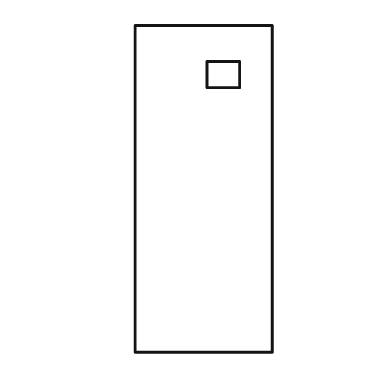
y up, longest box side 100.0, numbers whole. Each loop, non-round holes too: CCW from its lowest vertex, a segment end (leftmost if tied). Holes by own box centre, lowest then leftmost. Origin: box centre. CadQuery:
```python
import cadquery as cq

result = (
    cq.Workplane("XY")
    .moveTo(-21.0, -50.0)
    .lineTo(21.0, -50.0)
    .lineTo(21.0, 50.0)
    .lineTo(-21.0, 50.0)
    .close()
    .moveTo(1.0, 31.0)
    .lineTo(11.0, 31.0)
    .lineTo(11.0, 39.0)
    .lineTo(1.0, 39.0)
    .close()
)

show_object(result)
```